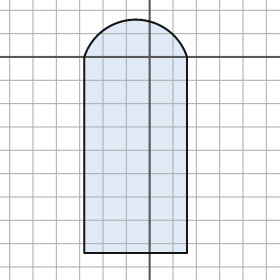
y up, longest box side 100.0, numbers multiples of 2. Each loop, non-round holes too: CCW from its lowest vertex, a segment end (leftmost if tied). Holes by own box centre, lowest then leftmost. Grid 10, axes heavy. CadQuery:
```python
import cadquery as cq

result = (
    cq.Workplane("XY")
    .moveTo(-28.0, -84.0)
    .lineTo(16.0, -84.0)
    .lineTo(16.0, 0.0)
    .threePointArc((-6.0, 16.0), (-28.0, 0.0))
    .close()
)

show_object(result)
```